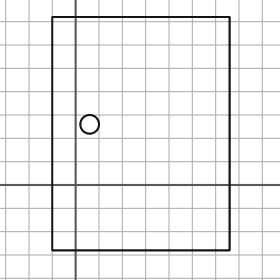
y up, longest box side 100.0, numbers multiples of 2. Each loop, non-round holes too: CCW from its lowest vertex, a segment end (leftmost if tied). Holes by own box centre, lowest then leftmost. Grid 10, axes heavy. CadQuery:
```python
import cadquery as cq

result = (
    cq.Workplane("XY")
    .moveTo(-10.0, -28.0)
    .lineTo(66.0, -28.0)
    .lineTo(66.0, 72.0)
    .lineTo(-10.0, 72.0)
    .close()
    .moveTo(6.0, 26.0)
    .circle(4.0)
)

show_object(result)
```